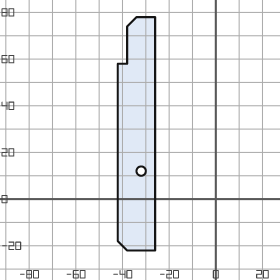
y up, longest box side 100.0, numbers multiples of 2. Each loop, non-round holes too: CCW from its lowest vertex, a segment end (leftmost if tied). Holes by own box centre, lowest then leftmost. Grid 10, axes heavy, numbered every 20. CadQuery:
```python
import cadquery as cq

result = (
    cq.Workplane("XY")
    .moveTo(-38.0, -22.0)
    .lineTo(-26.0, -22.0)
    .lineTo(-26.0, 78.0)
    .lineTo(-34.0, 78.0)
    .lineTo(-38.0, 74.0)
    .lineTo(-38.0, 58.0)
    .lineTo(-42.0, 58.0)
    .lineTo(-42.0, -18.0)
    .close()
    .moveTo(-32.0, 12.0)
    .circle(2.0)
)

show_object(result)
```